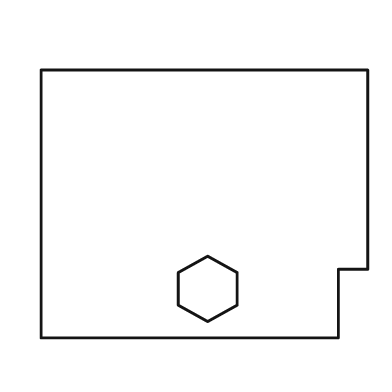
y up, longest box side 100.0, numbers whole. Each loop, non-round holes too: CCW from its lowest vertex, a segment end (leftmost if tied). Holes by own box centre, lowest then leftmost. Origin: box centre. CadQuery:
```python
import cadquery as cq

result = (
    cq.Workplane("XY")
    .moveTo(-50.0, -41.0)
    .lineTo(41.0, -41.0)
    .lineTo(41.0, -20.0)
    .lineTo(50.0, -20.0)
    .lineTo(50.0, 41.0)
    .lineTo(-50.0, 41.0)
    .close()
    .moveTo(1.0, -36.0)
    .lineTo(10.0, -31.0)
    .lineTo(10.0, -21.0)
    .lineTo(1.0, -16.0)
    .lineTo(-8.0, -21.0)
    .lineTo(-8.0, -31.0)
    .close()
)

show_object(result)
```